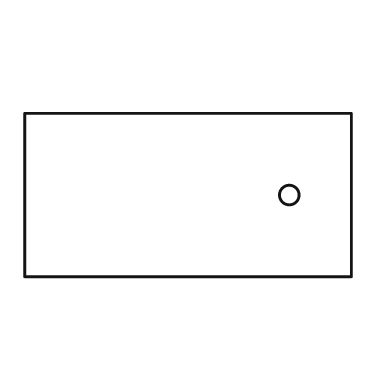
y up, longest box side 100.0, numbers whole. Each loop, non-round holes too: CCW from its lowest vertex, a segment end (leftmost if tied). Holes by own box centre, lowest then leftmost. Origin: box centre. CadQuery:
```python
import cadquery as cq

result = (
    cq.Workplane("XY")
    .moveTo(-50.0, -25.0)
    .lineTo(50.0, -25.0)
    .lineTo(50.0, 25.0)
    .lineTo(-50.0, 25.0)
    .close()
    .moveTo(31.0, 0.0)
    .circle(3.0)
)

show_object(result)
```